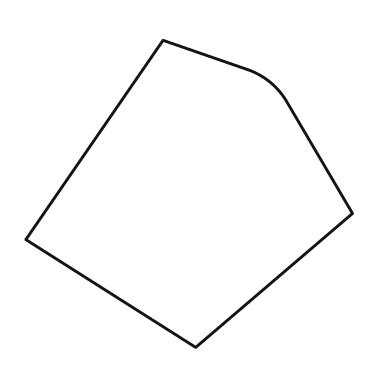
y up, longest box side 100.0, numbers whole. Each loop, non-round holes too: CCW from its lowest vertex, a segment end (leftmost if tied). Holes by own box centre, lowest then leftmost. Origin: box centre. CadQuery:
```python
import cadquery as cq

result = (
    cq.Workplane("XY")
    .moveTo(2.0, -47.0)
    .lineTo(50.0, -6.0)
    .lineTo(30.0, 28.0)
    .threePointArc((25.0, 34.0), (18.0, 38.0))
    .lineTo(-8.0, 47.0)
    .lineTo(-50.0, -14.0)
    .close()
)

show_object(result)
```